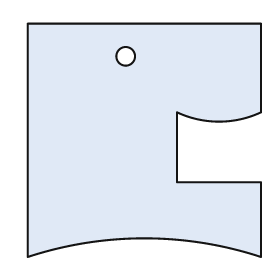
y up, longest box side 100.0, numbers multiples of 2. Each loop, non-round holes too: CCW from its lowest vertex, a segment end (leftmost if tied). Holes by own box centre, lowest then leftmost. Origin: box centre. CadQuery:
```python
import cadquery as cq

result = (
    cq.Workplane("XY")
    .moveTo(-50.0, -50.0)
    .threePointArc((0.0, -42.0), (50.0, -50.0))
    .lineTo(50.0, -18.0)
    .lineTo(14.0, -18.0)
    .lineTo(14.0, 12.0)
    .threePointArc((32.0, 8.0), (50.0, 12.0))
    .lineTo(50.0, 50.0)
    .lineTo(-50.0, 50.0)
    .close()
    .moveTo(-8.0, 36.0)
    .circle(4.0)
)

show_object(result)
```